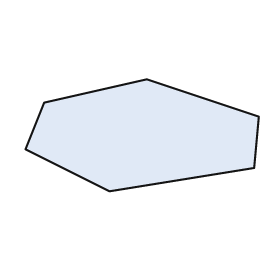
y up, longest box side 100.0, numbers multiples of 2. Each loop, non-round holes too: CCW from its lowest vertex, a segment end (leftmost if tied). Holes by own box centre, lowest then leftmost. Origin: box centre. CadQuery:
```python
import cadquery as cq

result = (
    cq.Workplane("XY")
    .moveTo(-14.0, -24.0)
    .lineTo(48.0, -14.0)
    .lineTo(50.0, 8.0)
    .lineTo(2.0, 24.0)
    .lineTo(-42.0, 14.0)
    .lineTo(-50.0, -6.0)
    .close()
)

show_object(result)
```